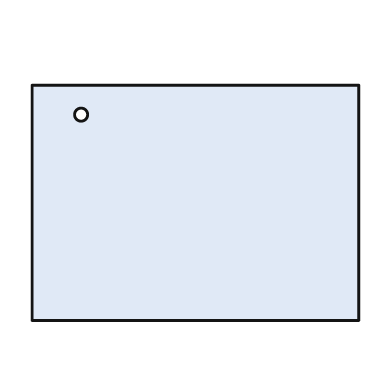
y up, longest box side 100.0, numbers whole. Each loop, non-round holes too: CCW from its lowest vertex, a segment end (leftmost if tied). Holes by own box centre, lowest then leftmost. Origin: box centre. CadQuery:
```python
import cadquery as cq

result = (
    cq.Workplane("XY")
    .moveTo(-50.0, -36.0)
    .lineTo(50.0, -36.0)
    .lineTo(50.0, 36.0)
    .lineTo(-50.0, 36.0)
    .close()
    .moveTo(-35.0, 27.0)
    .circle(2.0)
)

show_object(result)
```